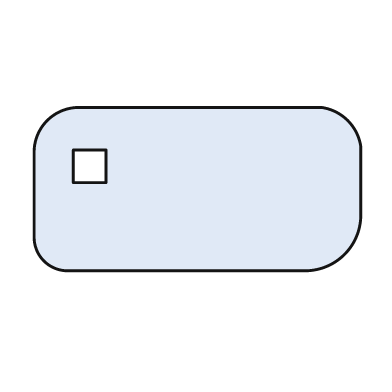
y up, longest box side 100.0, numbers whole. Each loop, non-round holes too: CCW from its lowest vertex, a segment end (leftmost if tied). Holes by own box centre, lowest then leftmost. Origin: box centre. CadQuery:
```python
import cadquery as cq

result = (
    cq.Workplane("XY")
    .moveTo(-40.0, -25.0)
    .lineTo(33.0, -25.0)
    .threePointArc((45.0, -20.0), (50.0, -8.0))
    .lineTo(50.0, 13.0)
    .threePointArc((46.0, 21.0), (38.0, 25.0))
    .lineTo(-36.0, 25.0)
    .threePointArc((-46.0, 21.0), (-50.0, 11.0))
    .lineTo(-50.0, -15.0)
    .threePointArc((-47.0, -22.0), (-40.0, -25.0))
    .close()
    .moveTo(-38.0, 2.0)
    .lineTo(-28.0, 2.0)
    .lineTo(-28.0, 12.0)
    .lineTo(-38.0, 12.0)
    .close()
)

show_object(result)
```